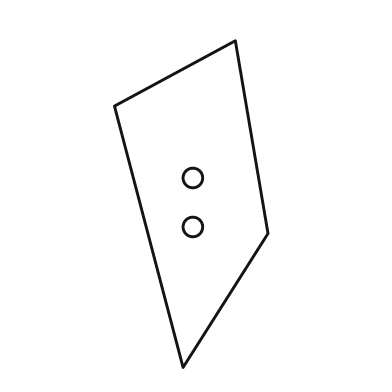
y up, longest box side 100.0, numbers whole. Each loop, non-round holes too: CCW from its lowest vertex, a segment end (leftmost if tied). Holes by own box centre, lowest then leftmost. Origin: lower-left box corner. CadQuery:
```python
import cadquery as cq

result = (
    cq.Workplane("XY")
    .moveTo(21.0, 0.0)
    .lineTo(47.0, 41.0)
    .lineTo(37.0, 100.0)
    .lineTo(0.0, 80.0)
    .close()
    .moveTo(24.0, 43.0)
    .circle(3.0)
    .moveTo(24.0, 58.0)
    .circle(3.0)
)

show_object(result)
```